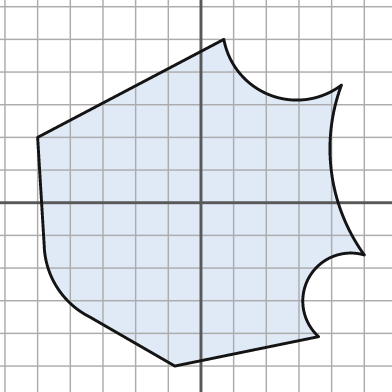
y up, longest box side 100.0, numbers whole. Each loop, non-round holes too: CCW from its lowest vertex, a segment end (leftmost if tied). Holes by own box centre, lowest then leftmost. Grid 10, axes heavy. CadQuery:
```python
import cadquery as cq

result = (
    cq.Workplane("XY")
    .moveTo(-8.0, -50.0)
    .lineTo(36.0, -41.0)
    .threePointArc((33.0, -23.0), (50.0, -16.0))
    .threePointArc((40.0, 9.0), (43.0, 36.0))
    .threePointArc((21.0, 33.0), (7.0, 50.0))
    .lineTo(-50.0, 20.0)
    .lineTo(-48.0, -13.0)
    .threePointArc((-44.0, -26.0), (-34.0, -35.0))
    .close()
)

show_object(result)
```